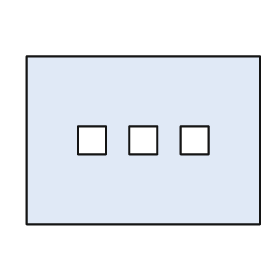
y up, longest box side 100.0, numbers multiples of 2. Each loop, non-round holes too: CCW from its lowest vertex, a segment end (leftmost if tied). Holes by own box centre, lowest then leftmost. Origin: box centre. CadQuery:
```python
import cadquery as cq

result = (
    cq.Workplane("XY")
    .moveTo(-50.0, -36.0)
    .lineTo(50.0, -36.0)
    .lineTo(50.0, 36.0)
    .lineTo(-50.0, 36.0)
    .close()
    .moveTo(-28.0, -6.0)
    .lineTo(-16.0, -6.0)
    .lineTo(-16.0, 6.0)
    .lineTo(-28.0, 6.0)
    .close()
    .moveTo(-6.0, -6.0)
    .lineTo(6.0, -6.0)
    .lineTo(6.0, 6.0)
    .lineTo(-6.0, 6.0)
    .close()
    .moveTo(16.0, -6.0)
    .lineTo(28.0, -6.0)
    .lineTo(28.0, 6.0)
    .lineTo(16.0, 6.0)
    .close()
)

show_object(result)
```